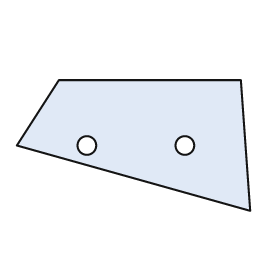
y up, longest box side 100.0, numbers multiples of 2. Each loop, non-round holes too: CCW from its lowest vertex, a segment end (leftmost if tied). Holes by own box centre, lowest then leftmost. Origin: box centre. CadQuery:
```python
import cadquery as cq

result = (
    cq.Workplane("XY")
    .moveTo(50.0, -28.0)
    .lineTo(46.0, 28.0)
    .lineTo(-32.0, 28.0)
    .lineTo(-50.0, 0.0)
    .close()
    .moveTo(-20.0, 0.0)
    .circle(4.0)
    .moveTo(22.0, 0.0)
    .circle(4.0)
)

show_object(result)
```